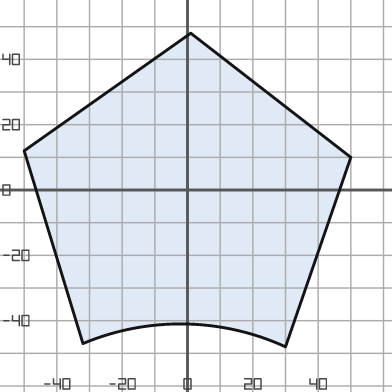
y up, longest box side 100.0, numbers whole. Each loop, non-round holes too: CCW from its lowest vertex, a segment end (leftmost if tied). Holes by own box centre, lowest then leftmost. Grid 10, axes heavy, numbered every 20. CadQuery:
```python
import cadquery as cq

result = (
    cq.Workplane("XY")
    .moveTo(30.0, -48.0)
    .lineTo(50.0, 10.0)
    .lineTo(1.0, 48.0)
    .lineTo(-50.0, 12.0)
    .lineTo(-32.0, -47.0)
    .threePointArc((-1.0, -41.0), (30.0, -48.0))
    .close()
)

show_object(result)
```